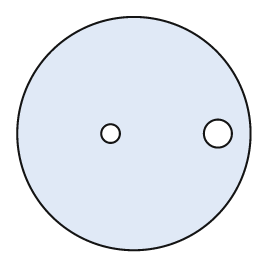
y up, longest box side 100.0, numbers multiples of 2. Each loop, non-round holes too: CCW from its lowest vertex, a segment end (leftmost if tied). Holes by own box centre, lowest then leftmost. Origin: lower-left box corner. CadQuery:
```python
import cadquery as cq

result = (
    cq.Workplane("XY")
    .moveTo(50.0, 50.0)
    .circle(50.0)
    .moveTo(40.0, 50.0)
    .circle(4.0)
    .moveTo(86.0, 50.0)
    .circle(6.0)
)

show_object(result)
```